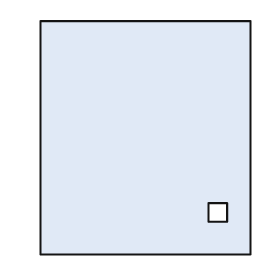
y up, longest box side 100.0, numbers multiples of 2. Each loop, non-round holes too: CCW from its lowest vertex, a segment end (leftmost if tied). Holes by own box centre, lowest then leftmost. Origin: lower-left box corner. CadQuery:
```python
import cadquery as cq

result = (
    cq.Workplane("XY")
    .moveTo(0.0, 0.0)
    .lineTo(90.0, 0.0)
    .lineTo(90.0, 100.0)
    .lineTo(0.0, 100.0)
    .close()
    .moveTo(72.0, 14.0)
    .lineTo(80.0, 14.0)
    .lineTo(80.0, 22.0)
    .lineTo(72.0, 22.0)
    .close()
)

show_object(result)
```